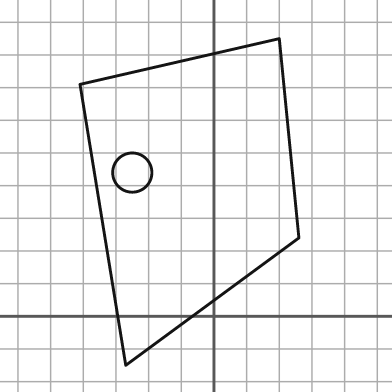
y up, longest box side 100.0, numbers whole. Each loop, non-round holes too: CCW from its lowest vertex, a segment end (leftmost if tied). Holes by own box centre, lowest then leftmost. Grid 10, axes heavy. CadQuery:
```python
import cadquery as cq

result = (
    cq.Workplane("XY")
    .moveTo(-27.0, -15.0)
    .lineTo(26.0, 24.0)
    .lineTo(20.0, 85.0)
    .lineTo(-41.0, 71.0)
    .close()
    .moveTo(-25.0, 44.0)
    .circle(6.0)
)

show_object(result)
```